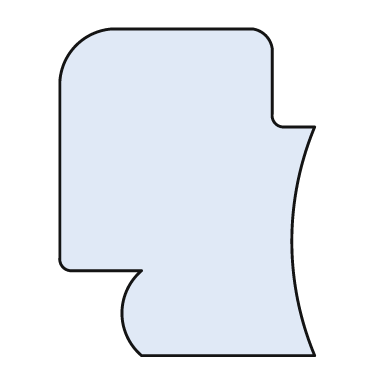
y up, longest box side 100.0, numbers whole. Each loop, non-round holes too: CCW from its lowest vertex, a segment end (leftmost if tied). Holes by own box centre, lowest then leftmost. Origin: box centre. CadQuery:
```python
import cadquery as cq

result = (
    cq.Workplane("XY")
    .moveTo(-14.0, -50.0)
    .lineTo(39.0, -50.0)
    .threePointArc((32.0, -15.0), (39.0, 20.0))
    .lineTo(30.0, 20.0)
    .threePointArc((27.0, 21.0), (26.0, 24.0))
    .lineTo(26.0, 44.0)
    .threePointArc((24.0, 48.0), (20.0, 50.0))
    .lineTo(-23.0, 50.0)
    .threePointArc((-34.0, 45.0), (-39.0, 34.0))
    .lineTo(-39.0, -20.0)
    .threePointArc((-38.0, -23.0), (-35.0, -24.0))
    .lineTo(-14.0, -24.0)
    .threePointArc((-20.0, -37.0), (-14.0, -50.0))
    .close()
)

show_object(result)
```